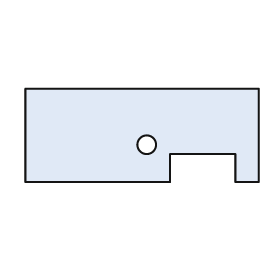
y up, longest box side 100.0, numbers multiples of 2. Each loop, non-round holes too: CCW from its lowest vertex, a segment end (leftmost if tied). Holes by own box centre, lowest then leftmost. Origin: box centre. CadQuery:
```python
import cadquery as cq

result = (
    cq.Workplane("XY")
    .moveTo(-50.0, -20.0)
    .lineTo(12.0, -20.0)
    .lineTo(12.0, -8.0)
    .lineTo(40.0, -8.0)
    .lineTo(40.0, -20.0)
    .lineTo(50.0, -20.0)
    .lineTo(50.0, 20.0)
    .lineTo(-50.0, 20.0)
    .close()
    .moveTo(2.0, -4.0)
    .circle(4.0)
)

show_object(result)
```